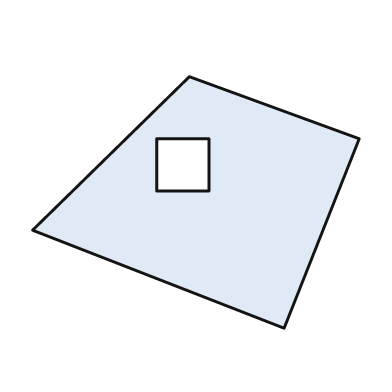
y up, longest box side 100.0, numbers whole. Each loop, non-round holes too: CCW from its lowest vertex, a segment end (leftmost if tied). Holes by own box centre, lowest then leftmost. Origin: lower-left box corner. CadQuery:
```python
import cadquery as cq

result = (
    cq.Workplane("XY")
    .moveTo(77.0, 0.0)
    .lineTo(100.0, 58.0)
    .lineTo(48.0, 77.0)
    .lineTo(0.0, 30.0)
    .close()
    .moveTo(38.0, 42.0)
    .lineTo(54.0, 42.0)
    .lineTo(54.0, 58.0)
    .lineTo(38.0, 58.0)
    .close()
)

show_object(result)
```